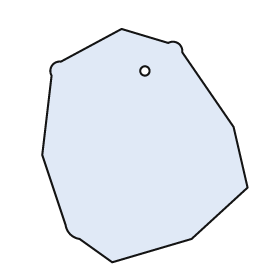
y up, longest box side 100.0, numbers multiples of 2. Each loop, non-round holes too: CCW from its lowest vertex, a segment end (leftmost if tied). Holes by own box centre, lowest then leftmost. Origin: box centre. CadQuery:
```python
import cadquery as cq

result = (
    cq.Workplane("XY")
    .moveTo(-14.0, -50.0)
    .lineTo(20.0, -40.0)
    .lineTo(44.0, -18.0)
    .lineTo(38.0, 8.0)
    .lineTo(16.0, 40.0)
    .threePointArc((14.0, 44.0), (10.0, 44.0))
    .lineTo(-10.0, 50.0)
    .lineTo(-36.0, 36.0)
    .threePointArc((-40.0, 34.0), (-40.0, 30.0))
    .lineTo(-44.0, -4.0)
    .lineTo(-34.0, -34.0)
    .threePointArc((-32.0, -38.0), (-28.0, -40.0))
    .close()
    .moveTo(0.0, 32.0)
    .circle(2.0)
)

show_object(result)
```